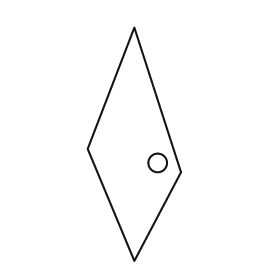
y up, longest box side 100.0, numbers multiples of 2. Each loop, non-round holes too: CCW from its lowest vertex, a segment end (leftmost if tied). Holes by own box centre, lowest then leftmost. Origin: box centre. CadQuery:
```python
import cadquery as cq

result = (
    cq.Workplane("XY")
    .moveTo(0.0, -50.0)
    .lineTo(20.0, -12.0)
    .lineTo(0.0, 50.0)
    .lineTo(-20.0, -2.0)
    .close()
    .moveTo(10.0, -8.0)
    .circle(4.0)
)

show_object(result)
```